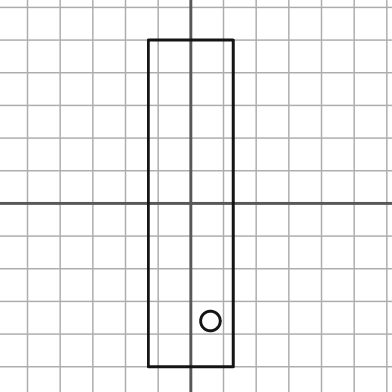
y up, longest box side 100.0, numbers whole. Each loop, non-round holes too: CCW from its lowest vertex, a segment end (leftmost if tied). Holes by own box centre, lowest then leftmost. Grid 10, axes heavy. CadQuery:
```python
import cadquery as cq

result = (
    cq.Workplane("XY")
    .moveTo(-13.0, -50.0)
    .lineTo(13.0, -50.0)
    .lineTo(13.0, 50.0)
    .lineTo(-13.0, 50.0)
    .close()
    .moveTo(6.0, -36.0)
    .circle(3.0)
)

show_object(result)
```